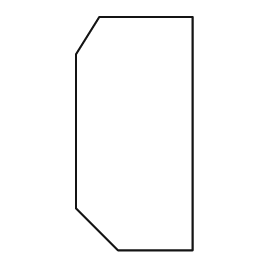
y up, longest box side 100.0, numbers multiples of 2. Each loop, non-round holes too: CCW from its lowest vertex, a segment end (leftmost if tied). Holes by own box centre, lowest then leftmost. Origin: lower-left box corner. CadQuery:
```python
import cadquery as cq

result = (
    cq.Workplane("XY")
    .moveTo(18.0, 0.0)
    .lineTo(50.0, 0.0)
    .lineTo(50.0, 100.0)
    .lineTo(10.0, 100.0)
    .lineTo(0.0, 84.0)
    .lineTo(0.0, 18.0)
    .close()
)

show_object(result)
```